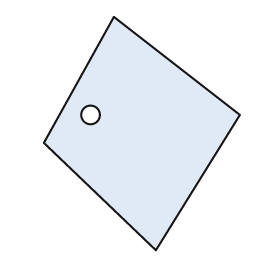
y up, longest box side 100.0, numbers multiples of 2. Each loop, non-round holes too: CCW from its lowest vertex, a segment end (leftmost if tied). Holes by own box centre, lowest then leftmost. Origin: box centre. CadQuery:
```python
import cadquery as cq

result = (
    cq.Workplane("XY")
    .moveTo(6.0, -50.0)
    .lineTo(42.0, 8.0)
    .lineTo(-12.0, 50.0)
    .lineTo(-42.0, -4.0)
    .close()
    .moveTo(-22.0, 8.0)
    .circle(4.0)
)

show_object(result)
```